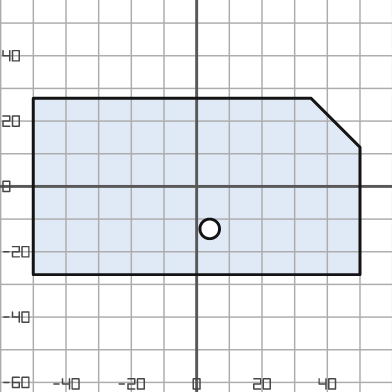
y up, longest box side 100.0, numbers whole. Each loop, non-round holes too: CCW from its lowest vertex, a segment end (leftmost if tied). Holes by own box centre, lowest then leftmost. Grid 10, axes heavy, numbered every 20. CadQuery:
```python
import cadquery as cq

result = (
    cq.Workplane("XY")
    .moveTo(-50.0, -27.0)
    .lineTo(50.0, -27.0)
    .lineTo(50.0, 12.0)
    .lineTo(35.0, 27.0)
    .lineTo(-50.0, 27.0)
    .close()
    .moveTo(4.0, -13.0)
    .circle(3.0)
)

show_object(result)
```